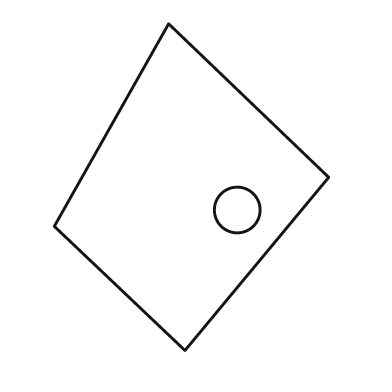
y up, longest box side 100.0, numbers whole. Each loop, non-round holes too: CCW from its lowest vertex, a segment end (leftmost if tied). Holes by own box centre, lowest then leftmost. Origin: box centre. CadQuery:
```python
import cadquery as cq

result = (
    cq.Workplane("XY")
    .moveTo(-2.0, -50.0)
    .lineTo(42.0, 3.0)
    .lineTo(-7.0, 50.0)
    .lineTo(-42.0, -12.0)
    .close()
    .moveTo(14.0, -7.0)
    .circle(7.0)
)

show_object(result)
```